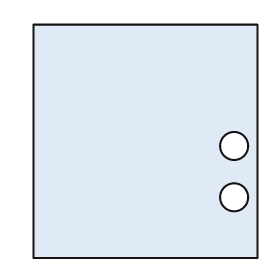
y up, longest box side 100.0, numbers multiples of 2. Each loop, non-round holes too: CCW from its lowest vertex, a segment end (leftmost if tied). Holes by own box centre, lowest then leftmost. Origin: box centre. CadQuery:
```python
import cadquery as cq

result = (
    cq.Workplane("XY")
    .moveTo(-48.0, -50.0)
    .lineTo(48.0, -50.0)
    .lineTo(48.0, 50.0)
    .lineTo(-48.0, 50.0)
    .close()
    .moveTo(38.0, -24.0)
    .circle(6.0)
    .moveTo(38.0, -2.0)
    .circle(6.0)
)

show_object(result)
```